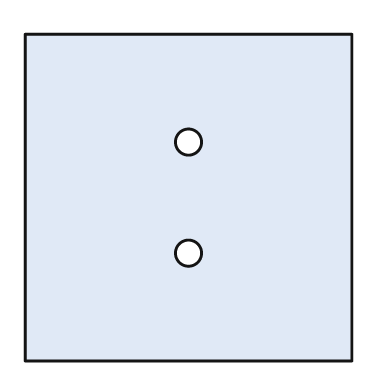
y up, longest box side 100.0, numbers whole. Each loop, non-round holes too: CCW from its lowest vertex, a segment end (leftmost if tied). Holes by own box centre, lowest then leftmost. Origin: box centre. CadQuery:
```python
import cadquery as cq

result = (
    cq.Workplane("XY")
    .moveTo(-50.0, -50.0)
    .lineTo(50.0, -50.0)
    .lineTo(50.0, 50.0)
    .lineTo(-50.0, 50.0)
    .close()
    .moveTo(0.0, -17.0)
    .circle(4.0)
    .moveTo(0.0, 17.0)
    .circle(4.0)
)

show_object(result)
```